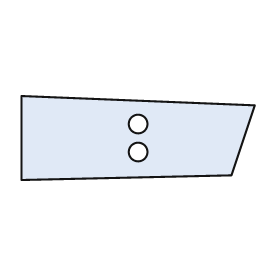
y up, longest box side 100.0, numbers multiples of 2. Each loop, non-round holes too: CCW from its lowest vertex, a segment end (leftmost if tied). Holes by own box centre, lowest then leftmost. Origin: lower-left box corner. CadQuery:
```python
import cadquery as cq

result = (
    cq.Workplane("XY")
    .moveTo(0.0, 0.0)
    .lineTo(90.0, 2.0)
    .lineTo(100.0, 32.0)
    .lineTo(0.0, 36.0)
    .close()
    .moveTo(50.0, 12.0)
    .circle(4.0)
    .moveTo(50.0, 24.0)
    .circle(4.0)
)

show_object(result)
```